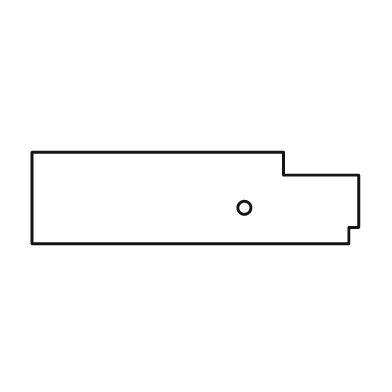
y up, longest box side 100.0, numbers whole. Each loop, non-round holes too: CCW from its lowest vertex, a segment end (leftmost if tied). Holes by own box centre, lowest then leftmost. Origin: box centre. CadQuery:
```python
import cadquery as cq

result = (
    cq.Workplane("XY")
    .moveTo(-50.0, -14.0)
    .lineTo(47.0, -14.0)
    .lineTo(47.0, -9.0)
    .lineTo(50.0, -9.0)
    .lineTo(50.0, 7.0)
    .lineTo(27.0, 7.0)
    .lineTo(27.0, 14.0)
    .lineTo(-50.0, 14.0)
    .close()
    .moveTo(15.0, -3.0)
    .circle(2.0)
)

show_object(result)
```